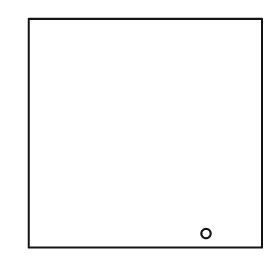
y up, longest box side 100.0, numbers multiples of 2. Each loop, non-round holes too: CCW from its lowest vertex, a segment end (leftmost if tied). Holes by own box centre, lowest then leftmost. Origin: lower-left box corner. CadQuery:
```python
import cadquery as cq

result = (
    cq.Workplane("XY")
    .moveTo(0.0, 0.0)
    .lineTo(100.0, 0.0)
    .lineTo(100.0, 98.0)
    .lineTo(0.0, 98.0)
    .close()
    .moveTo(76.0, 6.0)
    .circle(2.0)
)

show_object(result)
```